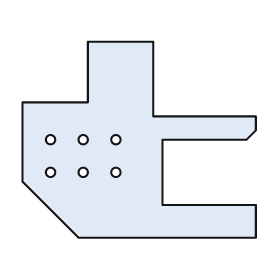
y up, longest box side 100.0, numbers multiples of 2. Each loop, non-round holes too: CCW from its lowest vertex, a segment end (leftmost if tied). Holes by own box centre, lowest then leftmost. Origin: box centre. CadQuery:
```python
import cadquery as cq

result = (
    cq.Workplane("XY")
    .moveTo(-26.0, -42.0)
    .lineTo(50.0, -42.0)
    .lineTo(50.0, -28.0)
    .lineTo(10.0, -28.0)
    .lineTo(10.0, 0.0)
    .lineTo(46.0, 0.0)
    .lineTo(50.0, 4.0)
    .lineTo(50.0, 10.0)
    .lineTo(6.0, 10.0)
    .lineTo(6.0, 42.0)
    .lineTo(-22.0, 42.0)
    .lineTo(-22.0, 16.0)
    .lineTo(-50.0, 16.0)
    .lineTo(-50.0, -18.0)
    .close()
    .moveTo(-38.0, -14.0)
    .circle(2.0)
    .moveTo(-24.0, -14.0)
    .circle(2.0)
    .moveTo(-10.0, -14.0)
    .circle(2.0)
    .moveTo(-38.0, 0.0)
    .circle(2.0)
    .moveTo(-24.0, 0.0)
    .circle(2.0)
    .moveTo(-10.0, 0.0)
    .circle(2.0)
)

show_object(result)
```